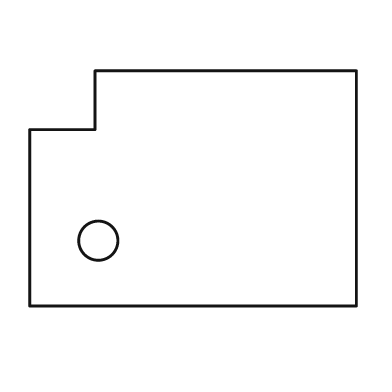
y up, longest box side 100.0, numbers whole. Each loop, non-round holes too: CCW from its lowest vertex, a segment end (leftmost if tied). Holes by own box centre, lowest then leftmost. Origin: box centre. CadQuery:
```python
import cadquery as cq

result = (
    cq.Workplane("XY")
    .moveTo(-50.0, -36.0)
    .lineTo(50.0, -36.0)
    .lineTo(50.0, 36.0)
    .lineTo(-30.0, 36.0)
    .lineTo(-30.0, 18.0)
    .lineTo(-50.0, 18.0)
    .close()
    .moveTo(-29.0, -16.0)
    .circle(6.0)
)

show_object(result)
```